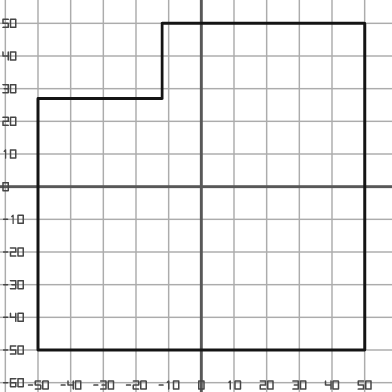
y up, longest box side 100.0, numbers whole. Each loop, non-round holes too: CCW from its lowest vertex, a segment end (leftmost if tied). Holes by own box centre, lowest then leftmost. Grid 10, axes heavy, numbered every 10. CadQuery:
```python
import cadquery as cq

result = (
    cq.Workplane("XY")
    .moveTo(-50.0, -50.0)
    .lineTo(50.0, -50.0)
    .lineTo(50.0, 50.0)
    .lineTo(-12.0, 50.0)
    .lineTo(-12.0, 27.0)
    .lineTo(-50.0, 27.0)
    .close()
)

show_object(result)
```